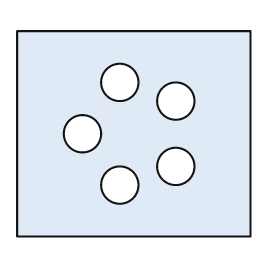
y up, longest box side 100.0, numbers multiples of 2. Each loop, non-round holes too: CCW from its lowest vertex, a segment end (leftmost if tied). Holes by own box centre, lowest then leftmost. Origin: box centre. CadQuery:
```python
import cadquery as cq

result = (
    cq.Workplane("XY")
    .moveTo(-50.0, -44.0)
    .lineTo(50.0, -44.0)
    .lineTo(50.0, 44.0)
    .lineTo(-50.0, 44.0)
    .close()
    .moveTo(-6.0, -22.0)
    .circle(8.0)
    .moveTo(18.0, -14.0)
    .circle(8.0)
    .moveTo(-22.0, 0.0)
    .circle(8.0)
    .moveTo(18.0, 14.0)
    .circle(8.0)
    .moveTo(-6.0, 22.0)
    .circle(8.0)
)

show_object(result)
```